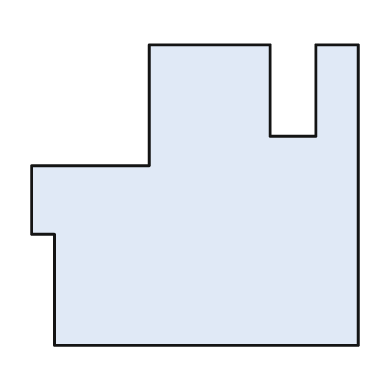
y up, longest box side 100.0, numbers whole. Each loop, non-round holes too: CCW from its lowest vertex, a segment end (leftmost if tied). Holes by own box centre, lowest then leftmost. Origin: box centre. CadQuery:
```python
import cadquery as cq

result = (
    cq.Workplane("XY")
    .moveTo(-43.0, -46.0)
    .lineTo(50.0, -46.0)
    .lineTo(50.0, 46.0)
    .lineTo(37.0, 46.0)
    .lineTo(37.0, 18.0)
    .lineTo(23.0, 18.0)
    .lineTo(23.0, 46.0)
    .lineTo(-14.0, 46.0)
    .lineTo(-14.0, 9.0)
    .lineTo(-50.0, 9.0)
    .lineTo(-50.0, -12.0)
    .lineTo(-43.0, -12.0)
    .close()
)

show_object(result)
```